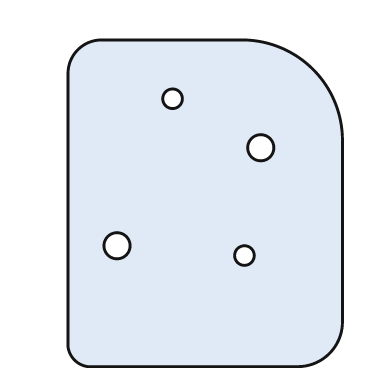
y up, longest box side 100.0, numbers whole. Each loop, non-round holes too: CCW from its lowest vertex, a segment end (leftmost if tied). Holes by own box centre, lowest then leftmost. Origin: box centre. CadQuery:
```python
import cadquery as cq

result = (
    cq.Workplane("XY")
    .moveTo(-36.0, -50.0)
    .lineTo(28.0, -50.0)
    .threePointArc((38.0, -46.0), (42.0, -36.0))
    .lineTo(42.0, 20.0)
    .threePointArc((33.0, 41.0), (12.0, 50.0))
    .lineTo(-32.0, 50.0)
    .threePointArc((-39.0, 47.0), (-42.0, 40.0))
    .lineTo(-42.0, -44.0)
    .threePointArc((-40.0, -48.0), (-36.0, -50.0))
    .close()
    .moveTo(12.0, -16.0)
    .circle(3.0)
    .moveTo(-27.0, -13.0)
    .circle(4.0)
    .moveTo(17.0, 17.0)
    .circle(4.0)
    .moveTo(-10.0, 32.0)
    .circle(3.0)
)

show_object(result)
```